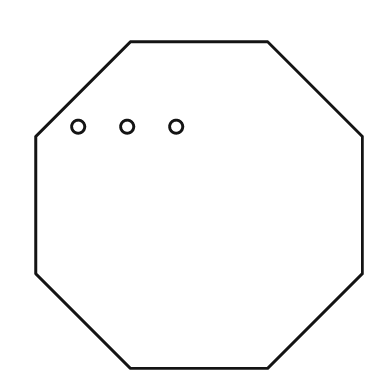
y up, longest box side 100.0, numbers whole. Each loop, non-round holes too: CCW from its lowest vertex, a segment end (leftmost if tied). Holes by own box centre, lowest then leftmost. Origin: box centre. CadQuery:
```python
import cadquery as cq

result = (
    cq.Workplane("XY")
    .moveTo(-21.0, -50.0)
    .lineTo(21.0, -50.0)
    .lineTo(50.0, -21.0)
    .lineTo(50.0, 21.0)
    .lineTo(21.0, 50.0)
    .lineTo(-21.0, 50.0)
    .lineTo(-50.0, 21.0)
    .lineTo(-50.0, -21.0)
    .close()
    .moveTo(-37.0, 24.0)
    .circle(2.0)
    .moveTo(-22.0, 24.0)
    .circle(2.0)
    .moveTo(-7.0, 24.0)
    .circle(2.0)
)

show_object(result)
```